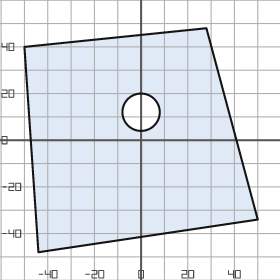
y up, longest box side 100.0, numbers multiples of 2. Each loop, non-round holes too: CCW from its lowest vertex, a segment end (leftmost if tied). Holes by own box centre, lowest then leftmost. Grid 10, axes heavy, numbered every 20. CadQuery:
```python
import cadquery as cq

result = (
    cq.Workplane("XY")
    .moveTo(-44.0, -48.0)
    .lineTo(50.0, -34.0)
    .lineTo(28.0, 48.0)
    .lineTo(-50.0, 40.0)
    .close()
    .moveTo(0.0, 12.0)
    .circle(8.0)
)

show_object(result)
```